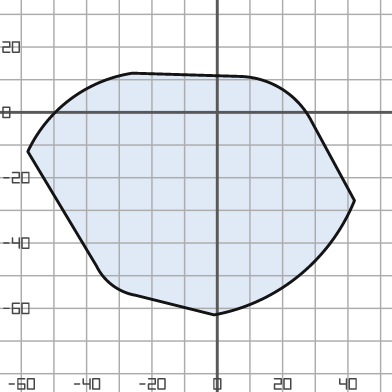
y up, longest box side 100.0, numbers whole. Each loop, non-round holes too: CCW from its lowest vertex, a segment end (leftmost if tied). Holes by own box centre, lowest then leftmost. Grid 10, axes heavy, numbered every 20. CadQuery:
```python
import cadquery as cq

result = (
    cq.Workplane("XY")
    .moveTo(-1.0, -62.0)
    .threePointArc((25.0, -50.0), (42.0, -27.0))
    .lineTo(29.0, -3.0)
    .threePointArc((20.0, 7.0), (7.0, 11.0))
    .lineTo(-26.0, 12.0)
    .threePointArc((-45.0, 4.0), (-58.0, -12.0))
    .lineTo(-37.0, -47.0)
    .threePointArc((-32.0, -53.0), (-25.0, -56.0))
    .close()
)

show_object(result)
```